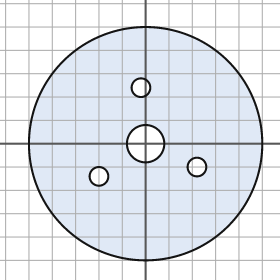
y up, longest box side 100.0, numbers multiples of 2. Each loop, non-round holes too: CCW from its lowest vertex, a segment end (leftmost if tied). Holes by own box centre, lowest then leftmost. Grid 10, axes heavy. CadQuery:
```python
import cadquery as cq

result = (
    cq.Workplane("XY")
    .moveTo(0.0, 0.0)
    .circle(50.0)
    .moveTo(-20.0, -14.0)
    .circle(4.0)
    .moveTo(22.0, -10.0)
    .circle(4.0)
    .moveTo(0.0, 0.0)
    .circle(8.0)
    .moveTo(-2.0, 24.0)
    .circle(4.0)
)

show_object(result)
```